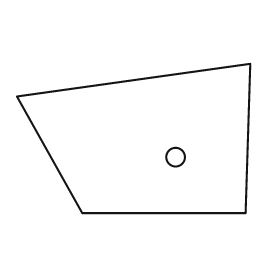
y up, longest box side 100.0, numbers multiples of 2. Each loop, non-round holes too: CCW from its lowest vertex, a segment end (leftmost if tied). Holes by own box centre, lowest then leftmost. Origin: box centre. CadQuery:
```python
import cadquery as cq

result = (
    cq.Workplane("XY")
    .moveTo(-22.0, -32.0)
    .lineTo(48.0, -32.0)
    .lineTo(50.0, 32.0)
    .lineTo(-50.0, 18.0)
    .close()
    .moveTo(18.0, -8.0)
    .circle(4.0)
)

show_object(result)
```